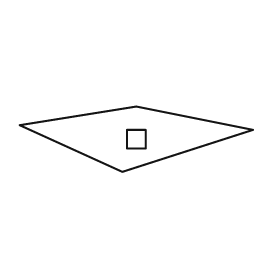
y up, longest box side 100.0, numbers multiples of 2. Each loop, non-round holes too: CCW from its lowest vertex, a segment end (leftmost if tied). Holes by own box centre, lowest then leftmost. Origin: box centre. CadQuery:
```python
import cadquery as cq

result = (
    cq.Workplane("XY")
    .moveTo(-6.0, -14.0)
    .lineTo(50.0, 4.0)
    .lineTo(0.0, 14.0)
    .lineTo(-50.0, 6.0)
    .close()
    .moveTo(-4.0, -4.0)
    .lineTo(4.0, -4.0)
    .lineTo(4.0, 4.0)
    .lineTo(-4.0, 4.0)
    .close()
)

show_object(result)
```